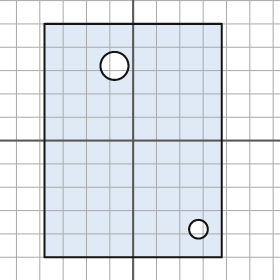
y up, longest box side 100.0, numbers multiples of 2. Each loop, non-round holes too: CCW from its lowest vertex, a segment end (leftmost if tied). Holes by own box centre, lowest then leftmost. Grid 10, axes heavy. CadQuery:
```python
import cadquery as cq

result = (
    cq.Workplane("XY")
    .moveTo(-38.0, -50.0)
    .lineTo(38.0, -50.0)
    .lineTo(38.0, 50.0)
    .lineTo(-38.0, 50.0)
    .close()
    .moveTo(28.0, -38.0)
    .circle(4.0)
    .moveTo(-8.0, 32.0)
    .circle(6.0)
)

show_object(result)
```